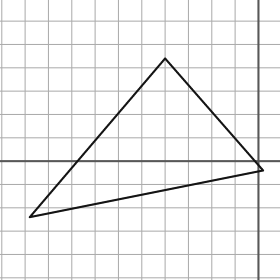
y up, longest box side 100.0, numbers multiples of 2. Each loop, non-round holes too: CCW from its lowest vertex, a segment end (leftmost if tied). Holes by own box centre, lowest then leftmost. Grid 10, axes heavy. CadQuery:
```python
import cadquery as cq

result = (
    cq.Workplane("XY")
    .moveTo(-98.0, -24.0)
    .lineTo(2.0, -4.0)
    .lineTo(-40.0, 44.0)
    .close()
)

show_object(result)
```